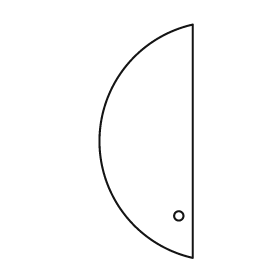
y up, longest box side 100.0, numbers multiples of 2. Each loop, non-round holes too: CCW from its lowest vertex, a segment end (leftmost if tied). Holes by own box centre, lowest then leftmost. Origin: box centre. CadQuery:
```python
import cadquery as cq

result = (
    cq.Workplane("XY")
    .moveTo(20.0, -50.0)
    .lineTo(20.0, 50.0)
    .threePointArc((-20.0, 0.0), (20.0, -50.0))
    .close()
    .moveTo(14.0, -32.0)
    .circle(2.0)
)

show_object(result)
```